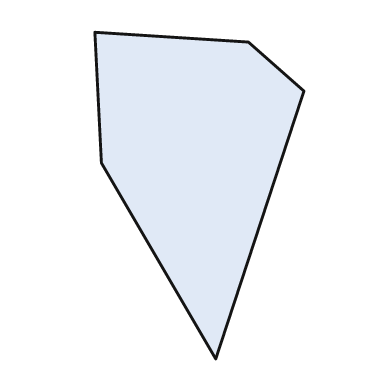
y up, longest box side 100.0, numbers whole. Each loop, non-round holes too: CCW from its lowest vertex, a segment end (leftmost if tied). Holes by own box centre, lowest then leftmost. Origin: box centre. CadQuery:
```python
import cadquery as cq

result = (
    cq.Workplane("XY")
    .moveTo(5.0, -50.0)
    .lineTo(32.0, 32.0)
    .lineTo(15.0, 47.0)
    .lineTo(-32.0, 50.0)
    .lineTo(-30.0, 10.0)
    .close()
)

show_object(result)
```